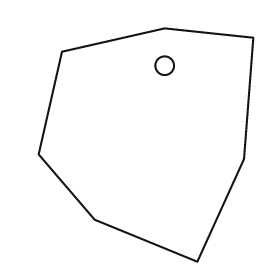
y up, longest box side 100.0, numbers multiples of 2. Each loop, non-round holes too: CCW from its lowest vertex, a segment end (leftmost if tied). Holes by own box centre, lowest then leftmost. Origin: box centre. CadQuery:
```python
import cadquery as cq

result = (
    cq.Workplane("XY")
    .moveTo(22.0, -50.0)
    .lineTo(42.0, -6.0)
    .lineTo(46.0, 46.0)
    .lineTo(8.0, 50.0)
    .lineTo(-36.0, 40.0)
    .lineTo(-46.0, -4.0)
    .lineTo(-22.0, -32.0)
    .close()
    .moveTo(8.0, 34.0)
    .circle(4.0)
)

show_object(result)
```